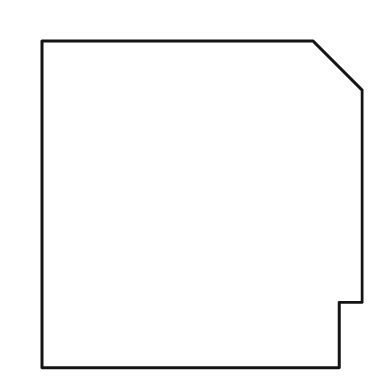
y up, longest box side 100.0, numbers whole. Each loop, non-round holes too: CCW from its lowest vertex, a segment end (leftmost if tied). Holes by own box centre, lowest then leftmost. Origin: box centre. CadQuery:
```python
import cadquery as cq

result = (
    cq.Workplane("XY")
    .moveTo(-49.0, -50.0)
    .lineTo(42.0, -50.0)
    .lineTo(42.0, -30.0)
    .lineTo(49.0, -30.0)
    .lineTo(49.0, 35.0)
    .lineTo(34.0, 50.0)
    .lineTo(-49.0, 50.0)
    .close()
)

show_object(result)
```